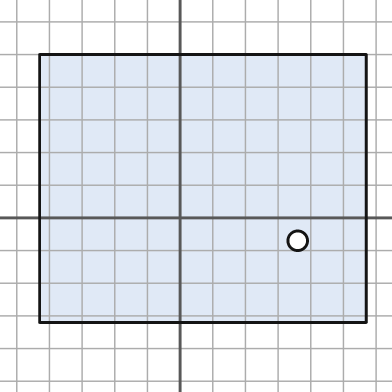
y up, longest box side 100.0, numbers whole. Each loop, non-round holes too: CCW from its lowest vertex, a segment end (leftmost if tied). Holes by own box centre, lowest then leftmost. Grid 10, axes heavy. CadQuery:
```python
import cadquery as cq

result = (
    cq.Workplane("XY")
    .moveTo(-43.0, -32.0)
    .lineTo(57.0, -32.0)
    .lineTo(57.0, 50.0)
    .lineTo(-43.0, 50.0)
    .close()
    .moveTo(36.0, -7.0)
    .circle(3.0)
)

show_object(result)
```